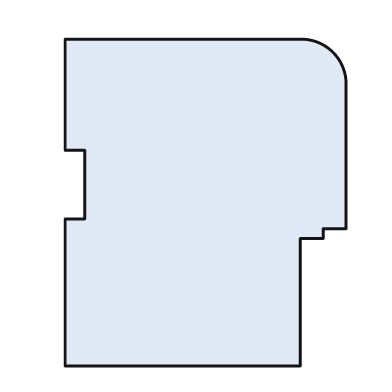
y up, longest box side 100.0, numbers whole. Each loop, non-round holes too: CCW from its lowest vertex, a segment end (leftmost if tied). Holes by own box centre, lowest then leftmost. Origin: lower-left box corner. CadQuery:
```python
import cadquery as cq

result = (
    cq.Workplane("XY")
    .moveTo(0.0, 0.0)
    .lineTo(72.0, 0.0)
    .lineTo(72.0, 39.0)
    .lineTo(79.0, 39.0)
    .lineTo(79.0, 42.0)
    .lineTo(86.0, 42.0)
    .lineTo(86.0, 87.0)
    .threePointArc((82.0, 96.0), (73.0, 100.0))
    .lineTo(0.0, 100.0)
    .lineTo(0.0, 66.0)
    .lineTo(6.0, 66.0)
    .lineTo(6.0, 45.0)
    .lineTo(0.0, 45.0)
    .close()
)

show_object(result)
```